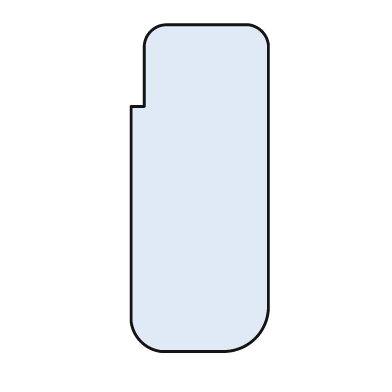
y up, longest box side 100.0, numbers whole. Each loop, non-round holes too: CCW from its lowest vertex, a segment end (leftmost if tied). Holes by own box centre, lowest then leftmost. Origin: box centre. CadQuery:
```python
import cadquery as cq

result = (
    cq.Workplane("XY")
    .moveTo(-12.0, -50.0)
    .lineTo(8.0, -50.0)
    .threePointArc((17.0, -46.0), (21.0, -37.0))
    .lineTo(21.0, 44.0)
    .threePointArc((19.0, 48.0), (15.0, 50.0))
    .lineTo(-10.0, 50.0)
    .threePointArc((-15.0, 48.0), (-17.0, 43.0))
    .lineTo(-17.0, 25.0)
    .lineTo(-21.0, 25.0)
    .lineTo(-21.0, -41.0)
    .threePointArc((-18.0, -47.0), (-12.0, -50.0))
    .close()
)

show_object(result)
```